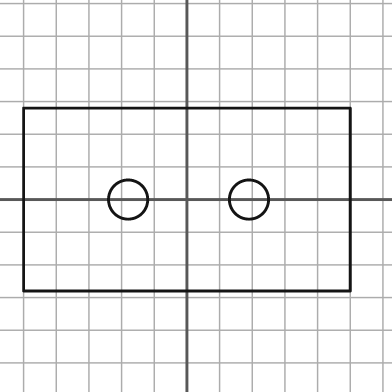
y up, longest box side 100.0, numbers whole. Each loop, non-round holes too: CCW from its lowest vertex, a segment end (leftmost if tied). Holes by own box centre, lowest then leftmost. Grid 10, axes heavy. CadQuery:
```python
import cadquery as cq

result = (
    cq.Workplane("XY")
    .moveTo(-50.0, -28.0)
    .lineTo(50.0, -28.0)
    .lineTo(50.0, 28.0)
    .lineTo(-50.0, 28.0)
    .close()
    .moveTo(-18.0, 0.0)
    .circle(6.0)
    .moveTo(19.0, 0.0)
    .circle(6.0)
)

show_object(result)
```